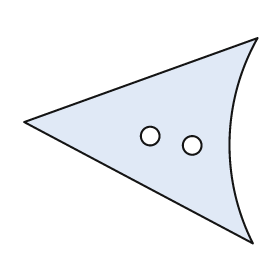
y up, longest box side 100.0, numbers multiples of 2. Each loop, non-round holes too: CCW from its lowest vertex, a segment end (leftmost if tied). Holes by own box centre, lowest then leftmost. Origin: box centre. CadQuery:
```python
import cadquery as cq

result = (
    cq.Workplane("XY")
    .moveTo(48.0, -44.0)
    .threePointArc((38.0, 0.0), (50.0, 44.0))
    .lineTo(-50.0, 8.0)
    .close()
    .moveTo(22.0, -2.0)
    .circle(4.0)
    .moveTo(4.0, 2.0)
    .circle(4.0)
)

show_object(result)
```